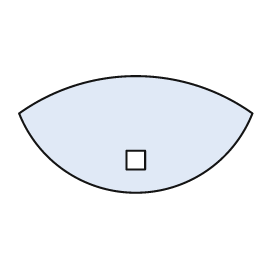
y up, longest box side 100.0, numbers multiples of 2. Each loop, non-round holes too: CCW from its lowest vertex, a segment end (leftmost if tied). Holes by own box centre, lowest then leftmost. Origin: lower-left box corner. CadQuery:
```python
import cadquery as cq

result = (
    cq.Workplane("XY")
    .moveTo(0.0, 34.0)
    .threePointArc((50.0, 0.0), (100.0, 34.0))
    .threePointArc((50.0, 50.0), (0.0, 34.0))
    .close()
    .moveTo(46.0, 10.0)
    .lineTo(54.0, 10.0)
    .lineTo(54.0, 18.0)
    .lineTo(46.0, 18.0)
    .close()
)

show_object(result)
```